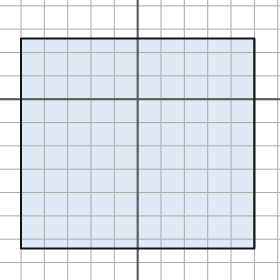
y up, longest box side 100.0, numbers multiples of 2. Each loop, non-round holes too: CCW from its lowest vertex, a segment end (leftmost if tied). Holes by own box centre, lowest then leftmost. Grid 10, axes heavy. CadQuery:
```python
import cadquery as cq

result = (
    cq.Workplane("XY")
    .moveTo(-50.0, -64.0)
    .lineTo(50.0, -64.0)
    .lineTo(50.0, 26.0)
    .lineTo(-50.0, 26.0)
    .close()
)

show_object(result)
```